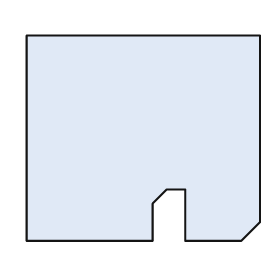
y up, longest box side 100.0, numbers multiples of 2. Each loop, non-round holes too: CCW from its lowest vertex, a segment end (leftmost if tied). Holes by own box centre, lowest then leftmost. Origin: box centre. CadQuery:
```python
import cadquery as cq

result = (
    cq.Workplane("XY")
    .moveTo(-50.0, -44.0)
    .lineTo(4.0, -44.0)
    .lineTo(4.0, -28.0)
    .lineTo(10.0, -22.0)
    .lineTo(18.0, -22.0)
    .lineTo(18.0, -44.0)
    .lineTo(42.0, -44.0)
    .lineTo(50.0, -36.0)
    .lineTo(50.0, 44.0)
    .lineTo(-50.0, 44.0)
    .close()
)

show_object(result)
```